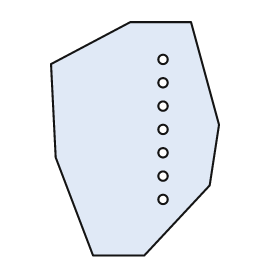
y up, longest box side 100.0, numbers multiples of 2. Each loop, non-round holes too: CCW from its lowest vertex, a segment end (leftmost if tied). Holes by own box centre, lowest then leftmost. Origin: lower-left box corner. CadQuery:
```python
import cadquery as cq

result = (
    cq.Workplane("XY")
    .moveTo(18.0, 0.0)
    .lineTo(40.0, 0.0)
    .lineTo(68.0, 30.0)
    .lineTo(72.0, 56.0)
    .lineTo(60.0, 100.0)
    .lineTo(34.0, 100.0)
    .lineTo(0.0, 82.0)
    .lineTo(2.0, 42.0)
    .close()
    .moveTo(48.0, 24.0)
    .circle(2.0)
    .moveTo(48.0, 34.0)
    .circle(2.0)
    .moveTo(48.0, 44.0)
    .circle(2.0)
    .moveTo(48.0, 54.0)
    .circle(2.0)
    .moveTo(48.0, 64.0)
    .circle(2.0)
    .moveTo(48.0, 74.0)
    .circle(2.0)
    .moveTo(48.0, 84.0)
    .circle(2.0)
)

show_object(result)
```